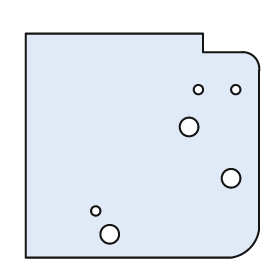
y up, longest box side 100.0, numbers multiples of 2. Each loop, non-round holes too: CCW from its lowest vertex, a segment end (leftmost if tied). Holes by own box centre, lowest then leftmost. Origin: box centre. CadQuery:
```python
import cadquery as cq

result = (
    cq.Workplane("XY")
    .moveTo(-50.0, -48.0)
    .lineTo(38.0, -48.0)
    .threePointArc((46.0, -44.0), (50.0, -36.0))
    .lineTo(50.0, 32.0)
    .threePointArc((48.0, 38.0), (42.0, 40.0))
    .lineTo(26.0, 40.0)
    .lineTo(26.0, 48.0)
    .lineTo(-50.0, 48.0)
    .close()
    .moveTo(-14.0, -38.0)
    .circle(4.0)
    .moveTo(-20.0, -28.0)
    .circle(2.0)
    .moveTo(38.0, -14.0)
    .circle(4.0)
    .moveTo(20.0, 8.0)
    .circle(4.0)
    .moveTo(24.0, 24.0)
    .circle(2.0)
    .moveTo(40.0, 24.0)
    .circle(2.0)
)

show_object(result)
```